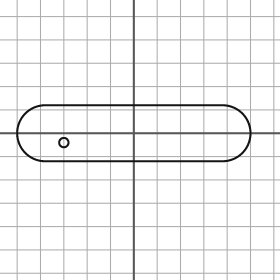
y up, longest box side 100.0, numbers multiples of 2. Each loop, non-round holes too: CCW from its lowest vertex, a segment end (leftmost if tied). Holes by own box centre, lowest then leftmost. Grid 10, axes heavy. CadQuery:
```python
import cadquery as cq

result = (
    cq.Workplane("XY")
    .moveTo(-38.0, -12.0)
    .lineTo(38.0, -12.0)
    .threePointArc((50.0, 0.0), (38.0, 12.0))
    .lineTo(-38.0, 12.0)
    .threePointArc((-50.0, 0.0), (-38.0, -12.0))
    .close()
    .moveTo(-30.0, -4.0)
    .circle(2.0)
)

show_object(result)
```